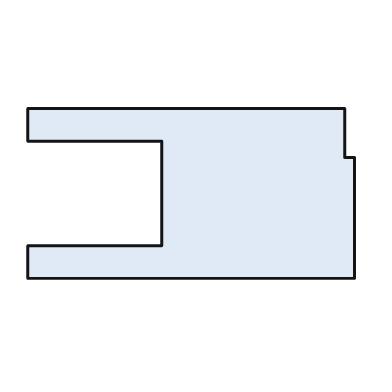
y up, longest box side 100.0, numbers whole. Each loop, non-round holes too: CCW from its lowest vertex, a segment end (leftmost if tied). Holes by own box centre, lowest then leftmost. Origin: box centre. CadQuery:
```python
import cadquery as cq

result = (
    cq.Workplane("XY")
    .moveTo(-50.0, -26.0)
    .lineTo(50.0, -26.0)
    .lineTo(50.0, 11.0)
    .lineTo(47.0, 11.0)
    .lineTo(47.0, 26.0)
    .lineTo(-50.0, 26.0)
    .lineTo(-50.0, 16.0)
    .lineTo(-9.0, 16.0)
    .lineTo(-9.0, -16.0)
    .lineTo(-50.0, -16.0)
    .close()
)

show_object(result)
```